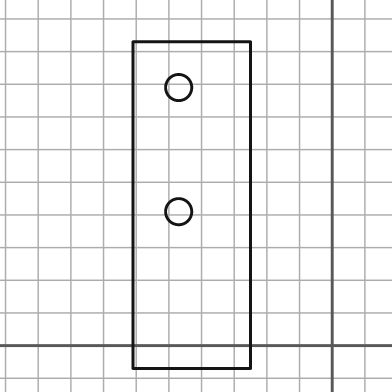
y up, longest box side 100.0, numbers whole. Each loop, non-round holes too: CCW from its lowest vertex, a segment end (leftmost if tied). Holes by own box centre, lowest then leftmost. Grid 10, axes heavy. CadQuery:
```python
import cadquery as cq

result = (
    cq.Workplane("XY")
    .moveTo(-61.0, -7.0)
    .lineTo(-25.0, -7.0)
    .lineTo(-25.0, 93.0)
    .lineTo(-61.0, 93.0)
    .close()
    .moveTo(-47.0, 41.0)
    .circle(4.0)
    .moveTo(-47.0, 79.0)
    .circle(4.0)
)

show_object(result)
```